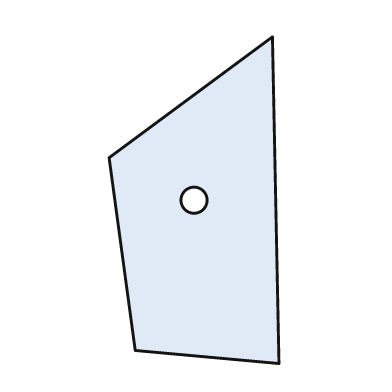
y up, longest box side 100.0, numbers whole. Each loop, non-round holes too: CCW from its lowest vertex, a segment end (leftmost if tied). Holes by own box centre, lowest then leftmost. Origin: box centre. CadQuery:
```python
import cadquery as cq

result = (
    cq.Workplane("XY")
    .moveTo(26.0, -50.0)
    .lineTo(24.0, 50.0)
    .lineTo(-26.0, 13.0)
    .lineTo(-18.0, -46.0)
    .close()
    .moveTo(0.0, 0.0)
    .circle(4.0)
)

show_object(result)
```